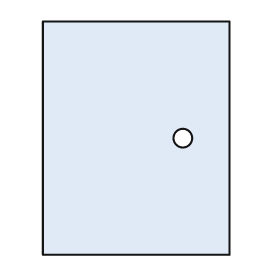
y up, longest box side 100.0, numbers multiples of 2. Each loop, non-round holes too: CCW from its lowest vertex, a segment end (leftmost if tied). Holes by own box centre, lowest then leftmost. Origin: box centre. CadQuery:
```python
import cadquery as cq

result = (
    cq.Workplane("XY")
    .moveTo(-40.0, -50.0)
    .lineTo(40.0, -50.0)
    .lineTo(40.0, 50.0)
    .lineTo(-40.0, 50.0)
    .close()
    .moveTo(20.0, 0.0)
    .circle(4.0)
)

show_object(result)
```